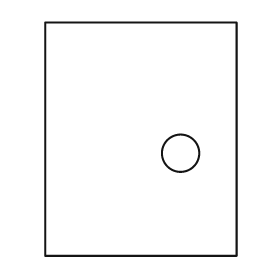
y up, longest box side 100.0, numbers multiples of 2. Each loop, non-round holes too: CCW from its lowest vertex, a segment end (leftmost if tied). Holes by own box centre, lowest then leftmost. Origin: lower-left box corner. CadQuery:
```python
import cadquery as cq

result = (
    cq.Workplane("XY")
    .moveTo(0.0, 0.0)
    .lineTo(82.0, 0.0)
    .lineTo(82.0, 100.0)
    .lineTo(0.0, 100.0)
    .close()
    .moveTo(58.0, 44.0)
    .circle(8.0)
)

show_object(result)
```